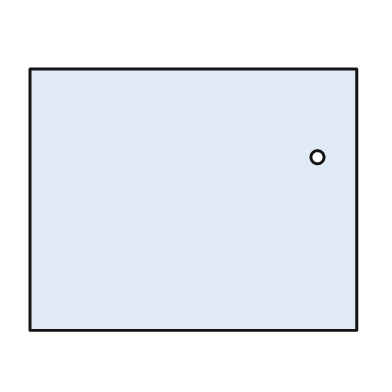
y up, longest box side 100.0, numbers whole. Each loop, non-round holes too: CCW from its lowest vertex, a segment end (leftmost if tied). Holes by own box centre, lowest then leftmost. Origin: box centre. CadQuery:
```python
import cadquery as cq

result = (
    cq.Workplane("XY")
    .moveTo(-50.0, -40.0)
    .lineTo(50.0, -40.0)
    .lineTo(50.0, 40.0)
    .lineTo(-50.0, 40.0)
    .close()
    .moveTo(38.0, 13.0)
    .circle(2.0)
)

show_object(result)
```